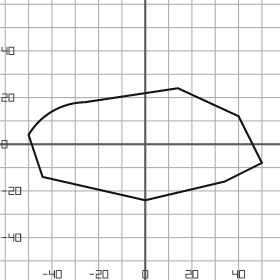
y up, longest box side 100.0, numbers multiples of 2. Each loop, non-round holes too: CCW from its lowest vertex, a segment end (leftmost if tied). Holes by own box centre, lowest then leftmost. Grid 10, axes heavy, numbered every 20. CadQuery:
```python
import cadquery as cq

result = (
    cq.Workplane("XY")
    .moveTo(0.0, -24.0)
    .lineTo(34.0, -16.0)
    .lineTo(50.0, -8.0)
    .lineTo(40.0, 12.0)
    .lineTo(14.0, 24.0)
    .lineTo(-26.0, 18.0)
    .threePointArc((-40.0, 14.0), (-50.0, 4.0))
    .lineTo(-44.0, -14.0)
    .close()
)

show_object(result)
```